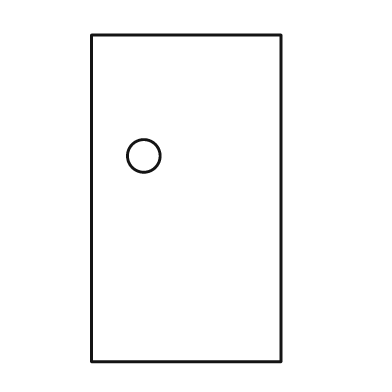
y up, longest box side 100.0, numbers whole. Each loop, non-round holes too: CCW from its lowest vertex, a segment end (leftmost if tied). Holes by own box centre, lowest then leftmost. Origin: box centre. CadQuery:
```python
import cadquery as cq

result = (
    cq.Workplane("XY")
    .moveTo(-29.0, -50.0)
    .lineTo(29.0, -50.0)
    .lineTo(29.0, 50.0)
    .lineTo(-29.0, 50.0)
    .close()
    .moveTo(-13.0, 13.0)
    .circle(5.0)
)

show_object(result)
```